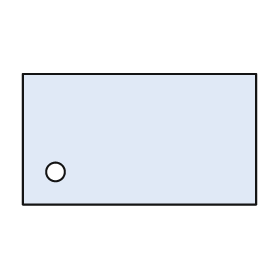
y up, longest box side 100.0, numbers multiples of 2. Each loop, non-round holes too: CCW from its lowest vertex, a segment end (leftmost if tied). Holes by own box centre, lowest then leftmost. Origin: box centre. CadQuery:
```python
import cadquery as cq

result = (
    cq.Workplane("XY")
    .moveTo(-50.0, -28.0)
    .lineTo(50.0, -28.0)
    .lineTo(50.0, 28.0)
    .lineTo(-50.0, 28.0)
    .close()
    .moveTo(-36.0, -14.0)
    .circle(4.0)
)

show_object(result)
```